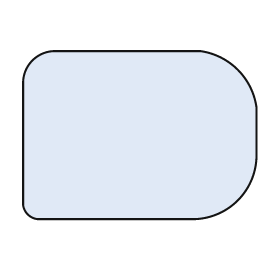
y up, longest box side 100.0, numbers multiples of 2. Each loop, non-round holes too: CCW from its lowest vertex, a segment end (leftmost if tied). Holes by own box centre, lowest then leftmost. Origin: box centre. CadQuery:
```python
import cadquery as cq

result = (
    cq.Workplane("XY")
    .moveTo(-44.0, -36.0)
    .lineTo(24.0, -36.0)
    .threePointArc((42.0, -28.0), (50.0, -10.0))
    .lineTo(50.0, 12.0)
    .threePointArc((42.0, 28.0), (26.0, 36.0))
    .lineTo(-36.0, 36.0)
    .threePointArc((-46.0, 32.0), (-50.0, 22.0))
    .lineTo(-50.0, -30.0)
    .threePointArc((-48.0, -34.0), (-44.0, -36.0))
    .close()
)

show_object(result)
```